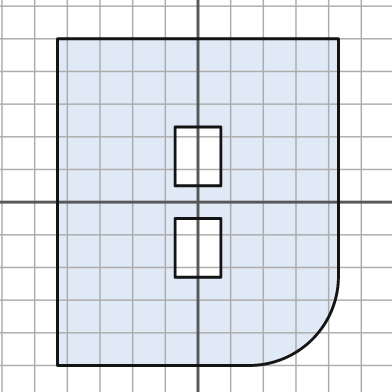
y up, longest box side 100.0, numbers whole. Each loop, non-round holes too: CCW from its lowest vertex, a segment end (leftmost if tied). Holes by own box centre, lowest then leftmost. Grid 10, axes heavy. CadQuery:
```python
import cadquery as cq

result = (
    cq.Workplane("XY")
    .moveTo(-43.0, -50.0)
    .lineTo(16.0, -50.0)
    .threePointArc((35.0, -42.0), (43.0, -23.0))
    .lineTo(43.0, 50.0)
    .lineTo(-43.0, 50.0)
    .close()
    .moveTo(-7.0, -23.0)
    .lineTo(7.0, -23.0)
    .lineTo(7.0, -5.0)
    .lineTo(-7.0, -5.0)
    .close()
    .moveTo(-7.0, 5.0)
    .lineTo(7.0, 5.0)
    .lineTo(7.0, 23.0)
    .lineTo(-7.0, 23.0)
    .close()
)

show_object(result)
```